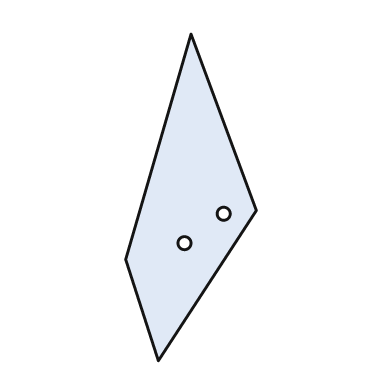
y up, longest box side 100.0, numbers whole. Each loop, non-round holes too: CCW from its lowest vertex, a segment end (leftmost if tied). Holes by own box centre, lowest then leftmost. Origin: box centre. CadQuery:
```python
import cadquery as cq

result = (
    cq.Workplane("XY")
    .moveTo(-10.0, -50.0)
    .lineTo(20.0, -4.0)
    .lineTo(0.0, 50.0)
    .lineTo(-20.0, -19.0)
    .close()
    .moveTo(-2.0, -14.0)
    .circle(2.0)
    .moveTo(10.0, -5.0)
    .circle(2.0)
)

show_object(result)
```